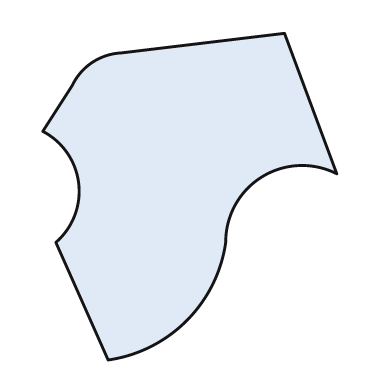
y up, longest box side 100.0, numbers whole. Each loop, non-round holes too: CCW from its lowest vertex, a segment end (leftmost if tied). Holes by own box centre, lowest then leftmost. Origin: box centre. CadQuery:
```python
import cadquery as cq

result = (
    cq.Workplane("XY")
    .moveTo(-25.0, -50.0)
    .threePointArc((-1.0, -38.0), (11.0, -14.0))
    .threePointArc((22.0, 6.0), (45.0, 7.0))
    .lineTo(29.0, 50.0)
    .lineTo(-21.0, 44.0)
    .threePointArc((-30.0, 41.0), (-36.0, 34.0))
    .lineTo(-45.0, 20.0)
    .threePointArc((-34.0, 4.0), (-41.0, -14.0))
    .close()
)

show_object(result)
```